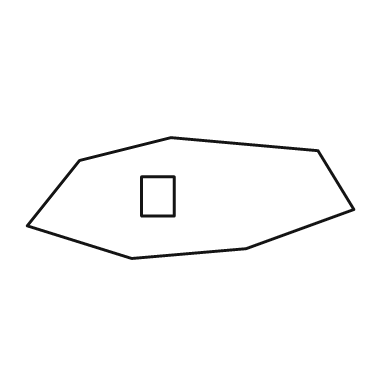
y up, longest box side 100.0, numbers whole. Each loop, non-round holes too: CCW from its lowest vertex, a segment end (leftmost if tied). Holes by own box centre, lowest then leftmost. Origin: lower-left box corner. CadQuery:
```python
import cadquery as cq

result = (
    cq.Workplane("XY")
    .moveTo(32.0, 0.0)
    .lineTo(67.0, 3.0)
    .lineTo(100.0, 15.0)
    .lineTo(89.0, 33.0)
    .lineTo(44.0, 37.0)
    .lineTo(16.0, 30.0)
    .lineTo(0.0, 10.0)
    .close()
    .moveTo(35.0, 13.0)
    .lineTo(45.0, 13.0)
    .lineTo(45.0, 25.0)
    .lineTo(35.0, 25.0)
    .close()
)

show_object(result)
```